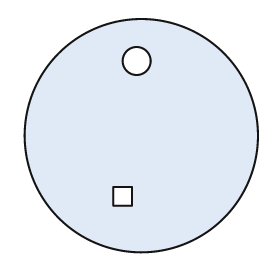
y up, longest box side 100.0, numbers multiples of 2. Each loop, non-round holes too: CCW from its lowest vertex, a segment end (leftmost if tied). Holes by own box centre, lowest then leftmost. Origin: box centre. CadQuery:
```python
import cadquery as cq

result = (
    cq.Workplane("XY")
    .moveTo(0.0, 0.0)
    .circle(50.0)
    .moveTo(-12.0, -30.0)
    .lineTo(-4.0, -30.0)
    .lineTo(-4.0, -22.0)
    .lineTo(-12.0, -22.0)
    .close()
    .moveTo(-2.0, 32.0)
    .circle(6.0)
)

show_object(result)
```